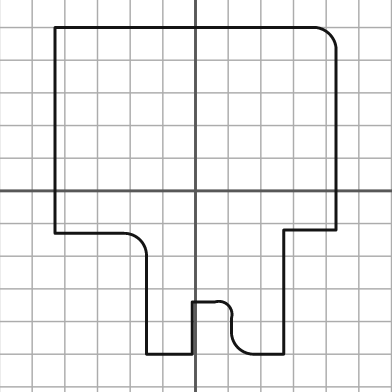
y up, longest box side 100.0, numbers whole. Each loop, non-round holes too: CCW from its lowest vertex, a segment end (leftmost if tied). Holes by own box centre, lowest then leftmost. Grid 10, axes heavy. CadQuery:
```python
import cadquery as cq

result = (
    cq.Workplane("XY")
    .moveTo(-15.0, -50.0)
    .lineTo(-1.0, -50.0)
    .lineTo(-1.0, -34.0)
    .lineTo(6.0, -34.0)
    .threePointArc((10.0, -35.0), (11.0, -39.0))
    .lineTo(11.0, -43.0)
    .threePointArc((13.0, -48.0), (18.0, -50.0))
    .lineTo(27.0, -50.0)
    .lineTo(27.0, -12.0)
    .lineTo(43.0, -12.0)
    .lineTo(43.0, 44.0)
    .threePointArc((41.0, 48.0), (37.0, 50.0))
    .lineTo(-43.0, 50.0)
    .lineTo(-43.0, -13.0)
    .lineTo(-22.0, -13.0)
    .threePointArc((-17.0, -15.0), (-15.0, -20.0))
    .close()
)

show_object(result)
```